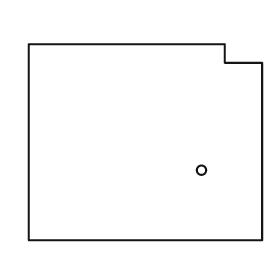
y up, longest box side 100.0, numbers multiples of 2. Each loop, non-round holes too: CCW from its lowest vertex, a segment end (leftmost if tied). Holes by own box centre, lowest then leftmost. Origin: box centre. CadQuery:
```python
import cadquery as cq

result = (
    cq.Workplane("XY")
    .moveTo(-50.0, -42.0)
    .lineTo(50.0, -42.0)
    .lineTo(50.0, 34.0)
    .lineTo(34.0, 34.0)
    .lineTo(34.0, 42.0)
    .lineTo(-50.0, 42.0)
    .close()
    .moveTo(24.0, -12.0)
    .circle(2.0)
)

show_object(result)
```